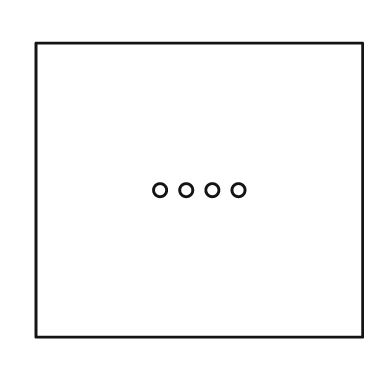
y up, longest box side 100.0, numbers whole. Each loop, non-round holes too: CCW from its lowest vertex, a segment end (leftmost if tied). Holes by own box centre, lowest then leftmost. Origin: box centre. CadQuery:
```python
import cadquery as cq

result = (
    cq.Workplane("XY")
    .moveTo(-50.0, -45.0)
    .lineTo(50.0, -45.0)
    .lineTo(50.0, 45.0)
    .lineTo(-50.0, 45.0)
    .close()
    .moveTo(-12.0, 0.0)
    .circle(2.0)
    .moveTo(-4.0, 0.0)
    .circle(2.0)
    .moveTo(4.0, 0.0)
    .circle(2.0)
    .moveTo(12.0, 0.0)
    .circle(2.0)
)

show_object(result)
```